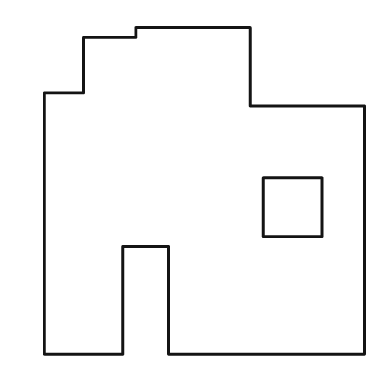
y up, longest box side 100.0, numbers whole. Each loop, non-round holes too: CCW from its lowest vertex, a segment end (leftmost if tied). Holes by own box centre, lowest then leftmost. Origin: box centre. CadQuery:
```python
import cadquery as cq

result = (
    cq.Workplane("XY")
    .moveTo(-49.0, -50.0)
    .lineTo(-25.0, -50.0)
    .lineTo(-25.0, -17.0)
    .lineTo(-11.0, -17.0)
    .lineTo(-11.0, -50.0)
    .lineTo(49.0, -50.0)
    .lineTo(49.0, 26.0)
    .lineTo(14.0, 26.0)
    .lineTo(14.0, 50.0)
    .lineTo(-21.0, 50.0)
    .lineTo(-21.0, 47.0)
    .lineTo(-37.0, 47.0)
    .lineTo(-37.0, 30.0)
    .lineTo(-49.0, 30.0)
    .close()
    .moveTo(18.0, -14.0)
    .lineTo(36.0, -14.0)
    .lineTo(36.0, 4.0)
    .lineTo(18.0, 4.0)
    .close()
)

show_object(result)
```